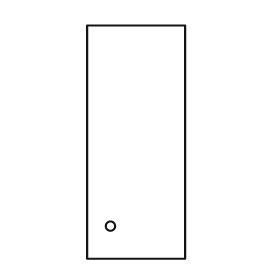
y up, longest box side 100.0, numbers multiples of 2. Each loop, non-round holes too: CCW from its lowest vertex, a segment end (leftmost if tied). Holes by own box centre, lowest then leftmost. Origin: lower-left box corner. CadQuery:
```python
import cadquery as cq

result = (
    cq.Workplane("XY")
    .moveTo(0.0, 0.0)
    .lineTo(42.0, 0.0)
    .lineTo(42.0, 100.0)
    .lineTo(0.0, 100.0)
    .close()
    .moveTo(10.0, 14.0)
    .circle(2.0)
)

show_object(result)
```